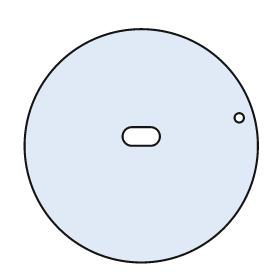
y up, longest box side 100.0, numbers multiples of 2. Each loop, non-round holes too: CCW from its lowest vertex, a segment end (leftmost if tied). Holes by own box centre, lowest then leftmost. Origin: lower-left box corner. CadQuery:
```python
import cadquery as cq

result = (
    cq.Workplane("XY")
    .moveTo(50.0, 50.0)
    .circle(50.0)
    .moveTo(46.0, 50.0)
    .lineTo(54.0, 50.0)
    .threePointArc((58.0, 54.0), (54.0, 58.0))
    .lineTo(46.0, 58.0)
    .threePointArc((42.0, 54.0), (46.0, 50.0))
    .close()
    .moveTo(92.0, 62.0)
    .circle(2.0)
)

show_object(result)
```